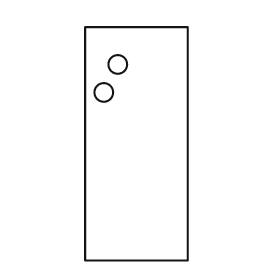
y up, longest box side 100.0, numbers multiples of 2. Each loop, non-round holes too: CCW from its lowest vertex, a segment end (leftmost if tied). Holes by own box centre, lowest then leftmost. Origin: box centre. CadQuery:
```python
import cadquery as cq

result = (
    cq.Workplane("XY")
    .moveTo(-22.0, -50.0)
    .lineTo(22.0, -50.0)
    .lineTo(22.0, 50.0)
    .lineTo(-22.0, 50.0)
    .close()
    .moveTo(-14.0, 22.0)
    .circle(4.0)
    .moveTo(-8.0, 34.0)
    .circle(4.0)
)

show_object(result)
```